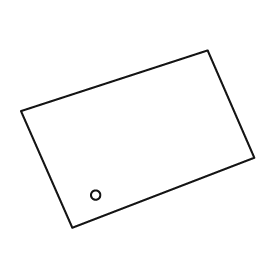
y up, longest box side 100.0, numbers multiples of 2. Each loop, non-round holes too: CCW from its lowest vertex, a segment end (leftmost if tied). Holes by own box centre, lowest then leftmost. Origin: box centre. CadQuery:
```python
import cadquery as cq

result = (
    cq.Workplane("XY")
    .moveTo(-28.0, -38.0)
    .lineTo(50.0, -8.0)
    .lineTo(30.0, 38.0)
    .lineTo(-50.0, 12.0)
    .close()
    .moveTo(-18.0, -24.0)
    .circle(2.0)
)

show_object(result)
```